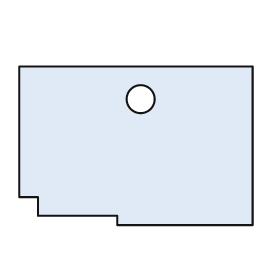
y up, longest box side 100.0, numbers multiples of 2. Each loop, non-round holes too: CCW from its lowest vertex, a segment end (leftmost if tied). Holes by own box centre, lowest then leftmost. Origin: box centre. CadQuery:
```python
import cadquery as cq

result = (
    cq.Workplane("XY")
    .moveTo(-8.0, -34.0)
    .lineTo(50.0, -34.0)
    .lineTo(50.0, 34.0)
    .lineTo(-50.0, 34.0)
    .lineTo(-50.0, -22.0)
    .lineTo(-42.0, -22.0)
    .lineTo(-42.0, -30.0)
    .lineTo(-8.0, -30.0)
    .close()
    .moveTo(2.0, 20.0)
    .circle(6.0)
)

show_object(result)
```